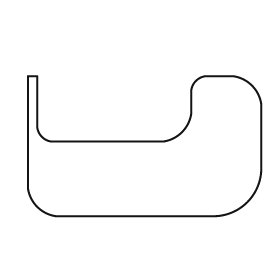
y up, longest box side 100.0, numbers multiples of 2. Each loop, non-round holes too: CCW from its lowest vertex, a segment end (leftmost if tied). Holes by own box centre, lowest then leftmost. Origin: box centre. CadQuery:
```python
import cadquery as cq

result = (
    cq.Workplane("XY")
    .moveTo(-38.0, -30.0)
    .lineTo(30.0, -30.0)
    .threePointArc((44.0, -24.0), (50.0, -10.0))
    .lineTo(50.0, 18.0)
    .threePointArc((46.0, 26.0), (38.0, 30.0))
    .lineTo(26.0, 30.0)
    .threePointArc((22.0, 28.0), (20.0, 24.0))
    .lineTo(20.0, 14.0)
    .threePointArc((16.0, 6.0), (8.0, 2.0))
    .lineTo(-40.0, 2.0)
    .threePointArc((-44.0, 4.0), (-46.0, 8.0))
    .lineTo(-46.0, 30.0)
    .lineTo(-50.0, 30.0)
    .lineTo(-50.0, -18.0)
    .threePointArc((-46.0, -26.0), (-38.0, -30.0))
    .close()
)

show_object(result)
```